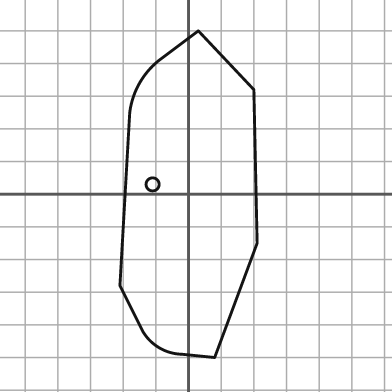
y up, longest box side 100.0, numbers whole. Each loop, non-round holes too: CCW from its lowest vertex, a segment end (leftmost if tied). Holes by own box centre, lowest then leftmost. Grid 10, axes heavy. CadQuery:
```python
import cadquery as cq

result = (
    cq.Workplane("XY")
    .moveTo(8.0, -50.0)
    .lineTo(21.0, -15.0)
    .lineTo(20.0, 32.0)
    .lineTo(3.0, 50.0)
    .lineTo(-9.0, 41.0)
    .threePointArc((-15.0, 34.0), (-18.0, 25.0))
    .lineTo(-21.0, -28.0)
    .lineTo(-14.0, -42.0)
    .threePointArc((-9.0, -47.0), (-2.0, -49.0))
    .close()
    .moveTo(-11.0, 3.0)
    .circle(2.0)
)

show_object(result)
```